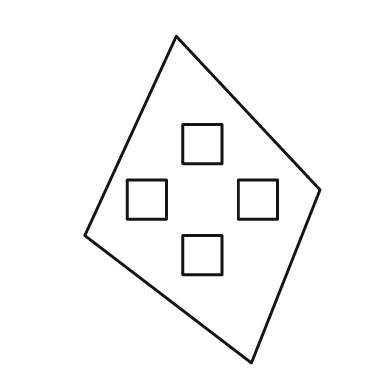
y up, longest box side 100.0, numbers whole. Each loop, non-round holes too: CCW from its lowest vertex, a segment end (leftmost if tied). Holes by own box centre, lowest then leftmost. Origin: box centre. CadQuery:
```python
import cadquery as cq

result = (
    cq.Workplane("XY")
    .moveTo(15.0, -50.0)
    .lineTo(36.0, 3.0)
    .lineTo(-8.0, 50.0)
    .lineTo(-36.0, -11.0)
    .close()
    .moveTo(-6.0, -23.0)
    .lineTo(6.0, -23.0)
    .lineTo(6.0, -11.0)
    .lineTo(-6.0, -11.0)
    .close()
    .moveTo(-23.0, -6.0)
    .lineTo(-11.0, -6.0)
    .lineTo(-11.0, 6.0)
    .lineTo(-23.0, 6.0)
    .close()
    .moveTo(11.0, -6.0)
    .lineTo(23.0, -6.0)
    .lineTo(23.0, 6.0)
    .lineTo(11.0, 6.0)
    .close()
    .moveTo(-6.0, 11.0)
    .lineTo(6.0, 11.0)
    .lineTo(6.0, 23.0)
    .lineTo(-6.0, 23.0)
    .close()
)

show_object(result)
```